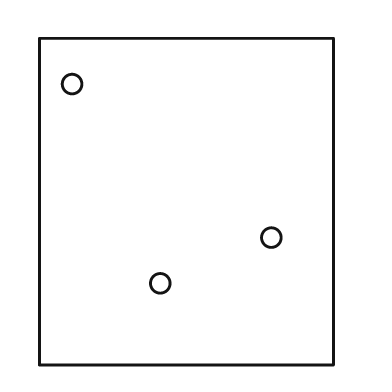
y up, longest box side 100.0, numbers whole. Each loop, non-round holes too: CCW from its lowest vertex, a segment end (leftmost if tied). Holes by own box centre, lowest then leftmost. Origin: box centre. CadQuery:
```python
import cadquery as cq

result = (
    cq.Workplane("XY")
    .moveTo(-45.0, -50.0)
    .lineTo(45.0, -50.0)
    .lineTo(45.0, 50.0)
    .lineTo(-45.0, 50.0)
    .close()
    .moveTo(-8.0, -25.0)
    .circle(3.0)
    .moveTo(26.0, -11.0)
    .circle(3.0)
    .moveTo(-35.0, 36.0)
    .circle(3.0)
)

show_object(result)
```